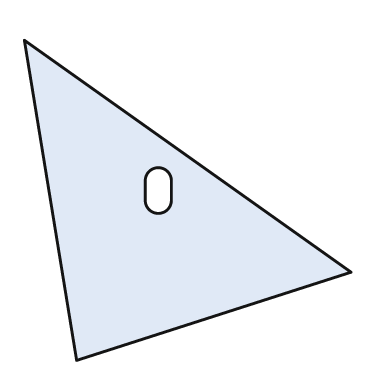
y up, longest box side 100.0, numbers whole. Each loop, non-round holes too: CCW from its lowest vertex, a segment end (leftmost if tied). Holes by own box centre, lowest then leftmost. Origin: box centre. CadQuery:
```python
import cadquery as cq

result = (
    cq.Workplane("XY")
    .moveTo(-34.0, -49.0)
    .lineTo(50.0, -22.0)
    .lineTo(-50.0, 49.0)
    .close()
    .moveTo(-13.0, 0.0)
    .threePointArc((-9.0, -4.0), (-5.0, 0.0))
    .lineTo(-5.0, 6.0)
    .threePointArc((-9.0, 10.0), (-13.0, 6.0))
    .close()
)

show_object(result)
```